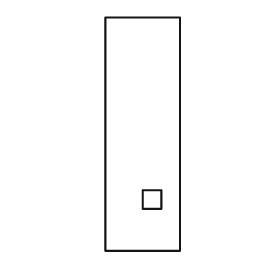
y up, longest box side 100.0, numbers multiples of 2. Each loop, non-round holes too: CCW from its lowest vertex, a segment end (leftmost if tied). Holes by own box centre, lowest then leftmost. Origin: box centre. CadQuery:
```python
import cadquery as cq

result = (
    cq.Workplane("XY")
    .moveTo(-16.0, -50.0)
    .lineTo(16.0, -50.0)
    .lineTo(16.0, 50.0)
    .lineTo(-16.0, 50.0)
    .close()
    .moveTo(0.0, -32.0)
    .lineTo(8.0, -32.0)
    .lineTo(8.0, -24.0)
    .lineTo(0.0, -24.0)
    .close()
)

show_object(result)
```